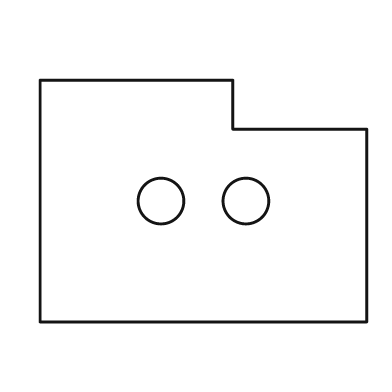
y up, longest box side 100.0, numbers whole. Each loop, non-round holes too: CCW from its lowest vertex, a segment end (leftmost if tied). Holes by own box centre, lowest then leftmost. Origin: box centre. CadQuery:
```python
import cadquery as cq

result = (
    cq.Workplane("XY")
    .moveTo(-50.0, -37.0)
    .lineTo(50.0, -37.0)
    .lineTo(50.0, 22.0)
    .lineTo(9.0, 22.0)
    .lineTo(9.0, 37.0)
    .lineTo(-50.0, 37.0)
    .close()
    .moveTo(-13.0, 0.0)
    .circle(7.0)
    .moveTo(13.0, 0.0)
    .circle(7.0)
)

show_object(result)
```